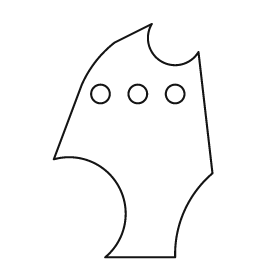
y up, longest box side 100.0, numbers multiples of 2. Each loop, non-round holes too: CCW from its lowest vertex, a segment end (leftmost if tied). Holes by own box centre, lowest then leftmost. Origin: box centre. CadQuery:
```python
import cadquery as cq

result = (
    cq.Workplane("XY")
    .moveTo(-12.0, -50.0)
    .lineTo(18.0, -50.0)
    .threePointArc((22.0, -30.0), (34.0, -14.0))
    .lineTo(28.0, 38.0)
    .threePointArc((12.0, 34.0), (8.0, 50.0))
    .lineTo(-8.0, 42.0)
    .threePointArc((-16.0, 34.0), (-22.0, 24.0))
    .lineTo(-34.0, -8.0)
    .threePointArc((-6.0, -20.0), (-12.0, -50.0))
    .close()
    .moveTo(-14.0, 20.0)
    .circle(4.0)
    .moveTo(2.0, 20.0)
    .circle(4.0)
    .moveTo(18.0, 20.0)
    .circle(4.0)
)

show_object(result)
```